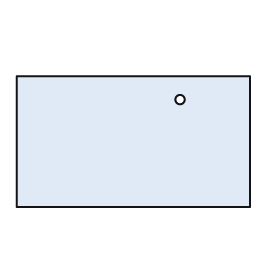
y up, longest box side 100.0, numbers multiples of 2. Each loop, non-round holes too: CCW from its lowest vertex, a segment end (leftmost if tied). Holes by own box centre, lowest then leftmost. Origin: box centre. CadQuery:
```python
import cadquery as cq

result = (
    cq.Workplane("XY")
    .moveTo(-50.0, -28.0)
    .lineTo(50.0, -28.0)
    .lineTo(50.0, 28.0)
    .lineTo(-50.0, 28.0)
    .close()
    .moveTo(20.0, 18.0)
    .circle(2.0)
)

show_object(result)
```